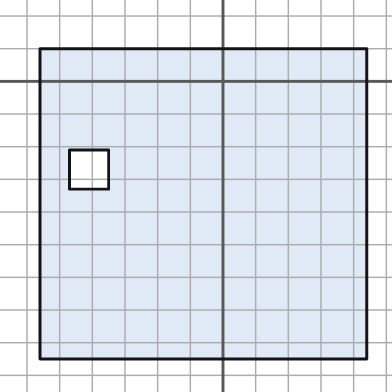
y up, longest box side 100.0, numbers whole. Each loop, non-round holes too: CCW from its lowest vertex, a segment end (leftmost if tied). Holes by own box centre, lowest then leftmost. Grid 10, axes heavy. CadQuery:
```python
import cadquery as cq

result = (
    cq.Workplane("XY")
    .moveTo(-56.0, -85.0)
    .lineTo(44.0, -85.0)
    .lineTo(44.0, 10.0)
    .lineTo(-56.0, 10.0)
    .close()
    .moveTo(-47.0, -33.0)
    .lineTo(-35.0, -33.0)
    .lineTo(-35.0, -21.0)
    .lineTo(-47.0, -21.0)
    .close()
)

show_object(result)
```